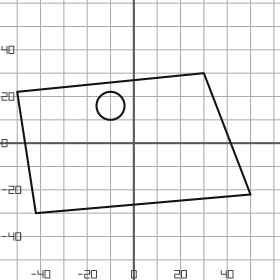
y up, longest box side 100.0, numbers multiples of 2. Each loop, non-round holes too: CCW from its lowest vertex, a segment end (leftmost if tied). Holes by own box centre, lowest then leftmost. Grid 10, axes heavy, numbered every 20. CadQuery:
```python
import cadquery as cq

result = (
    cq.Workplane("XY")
    .moveTo(-42.0, -30.0)
    .lineTo(50.0, -22.0)
    .lineTo(30.0, 30.0)
    .lineTo(-50.0, 22.0)
    .close()
    .moveTo(-10.0, 16.0)
    .circle(6.0)
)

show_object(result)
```